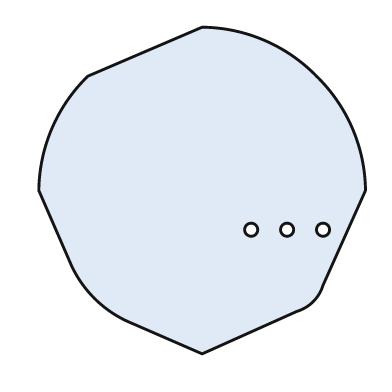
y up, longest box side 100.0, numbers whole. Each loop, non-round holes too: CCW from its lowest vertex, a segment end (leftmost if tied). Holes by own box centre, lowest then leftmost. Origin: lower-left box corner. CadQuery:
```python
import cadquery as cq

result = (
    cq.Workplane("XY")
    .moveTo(50.0, 0.0)
    .lineTo(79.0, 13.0)
    .threePointArc((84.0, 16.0), (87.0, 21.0))
    .lineTo(100.0, 50.0)
    .threePointArc((96.0, 69.0), (85.0, 85.0))
    .threePointArc((69.0, 96.0), (50.0, 100.0))
    .lineTo(15.0, 85.0)
    .threePointArc((4.0, 69.0), (0.0, 50.0))
    .lineTo(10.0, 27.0)
    .threePointArc((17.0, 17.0), (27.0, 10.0))
    .close()
    .moveTo(65.0, 38.0)
    .circle(2.0)
    .moveTo(76.0, 38.0)
    .circle(2.0)
    .moveTo(87.0, 38.0)
    .circle(2.0)
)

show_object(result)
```